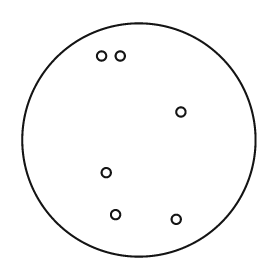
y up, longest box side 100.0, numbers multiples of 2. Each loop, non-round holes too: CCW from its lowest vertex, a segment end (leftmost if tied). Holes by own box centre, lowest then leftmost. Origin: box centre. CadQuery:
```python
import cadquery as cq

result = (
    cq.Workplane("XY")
    .moveTo(0.0, 0.0)
    .circle(50.0)
    .moveTo(16.0, -34.0)
    .circle(2.0)
    .moveTo(-10.0, -32.0)
    .circle(2.0)
    .moveTo(-14.0, -14.0)
    .circle(2.0)
    .moveTo(18.0, 12.0)
    .circle(2.0)
    .moveTo(-16.0, 36.0)
    .circle(2.0)
    .moveTo(-8.0, 36.0)
    .circle(2.0)
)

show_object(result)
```